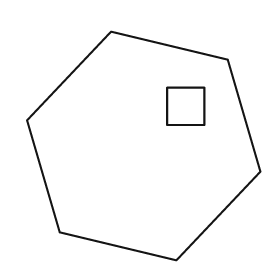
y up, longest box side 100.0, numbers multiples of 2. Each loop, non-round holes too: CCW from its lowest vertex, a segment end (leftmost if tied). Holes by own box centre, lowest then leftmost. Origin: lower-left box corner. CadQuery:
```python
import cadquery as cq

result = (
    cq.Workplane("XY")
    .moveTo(64.0, 0.0)
    .lineTo(100.0, 38.0)
    .lineTo(86.0, 86.0)
    .lineTo(36.0, 98.0)
    .lineTo(0.0, 60.0)
    .lineTo(14.0, 12.0)
    .close()
    .moveTo(60.0, 58.0)
    .lineTo(76.0, 58.0)
    .lineTo(76.0, 74.0)
    .lineTo(60.0, 74.0)
    .close()
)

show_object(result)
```